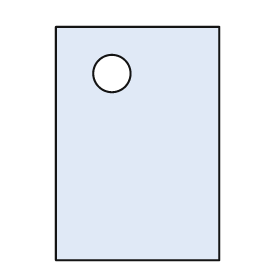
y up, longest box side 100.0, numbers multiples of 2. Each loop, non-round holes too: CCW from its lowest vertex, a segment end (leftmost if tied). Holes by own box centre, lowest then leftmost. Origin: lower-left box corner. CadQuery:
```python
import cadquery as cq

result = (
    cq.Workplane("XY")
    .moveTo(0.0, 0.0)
    .lineTo(70.0, 0.0)
    .lineTo(70.0, 100.0)
    .lineTo(0.0, 100.0)
    .close()
    .moveTo(24.0, 80.0)
    .circle(8.0)
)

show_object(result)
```